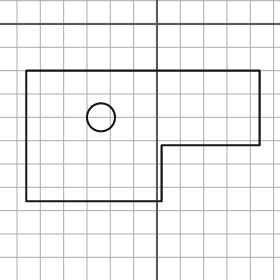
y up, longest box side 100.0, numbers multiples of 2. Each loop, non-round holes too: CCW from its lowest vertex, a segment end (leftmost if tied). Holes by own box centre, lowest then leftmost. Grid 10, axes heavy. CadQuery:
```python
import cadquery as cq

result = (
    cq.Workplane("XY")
    .moveTo(-56.0, -76.0)
    .lineTo(2.0, -76.0)
    .lineTo(2.0, -52.0)
    .lineTo(44.0, -52.0)
    .lineTo(44.0, -20.0)
    .lineTo(-56.0, -20.0)
    .close()
    .moveTo(-24.0, -40.0)
    .circle(6.0)
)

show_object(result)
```